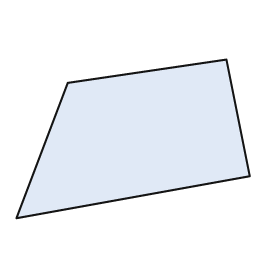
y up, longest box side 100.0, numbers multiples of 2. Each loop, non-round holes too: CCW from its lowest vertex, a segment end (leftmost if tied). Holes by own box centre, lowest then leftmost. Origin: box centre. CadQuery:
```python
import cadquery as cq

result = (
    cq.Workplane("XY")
    .moveTo(-50.0, -34.0)
    .lineTo(50.0, -16.0)
    .lineTo(40.0, 34.0)
    .lineTo(-28.0, 24.0)
    .close()
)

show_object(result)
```